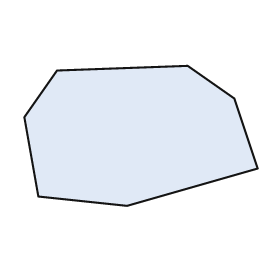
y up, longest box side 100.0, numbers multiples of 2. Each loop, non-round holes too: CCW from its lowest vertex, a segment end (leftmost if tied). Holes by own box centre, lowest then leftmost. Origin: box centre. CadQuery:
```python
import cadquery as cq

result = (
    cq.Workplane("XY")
    .moveTo(-6.0, -30.0)
    .lineTo(50.0, -14.0)
    .lineTo(40.0, 16.0)
    .lineTo(20.0, 30.0)
    .lineTo(-36.0, 28.0)
    .lineTo(-50.0, 8.0)
    .lineTo(-44.0, -26.0)
    .close()
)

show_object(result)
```